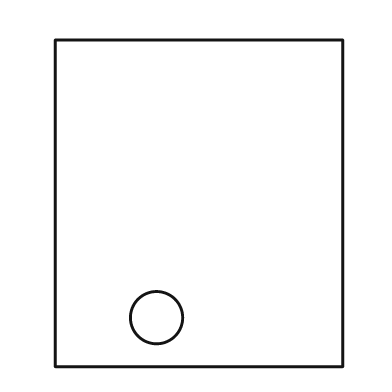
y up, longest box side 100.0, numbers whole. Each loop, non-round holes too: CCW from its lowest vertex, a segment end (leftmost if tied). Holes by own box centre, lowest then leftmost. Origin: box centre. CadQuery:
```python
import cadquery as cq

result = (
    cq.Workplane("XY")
    .moveTo(-44.0, -50.0)
    .lineTo(44.0, -50.0)
    .lineTo(44.0, 50.0)
    .lineTo(-44.0, 50.0)
    .close()
    .moveTo(-13.0, -35.0)
    .circle(8.0)
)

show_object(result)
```